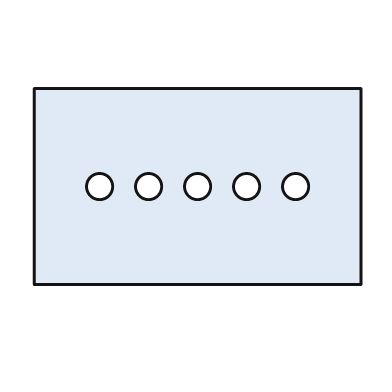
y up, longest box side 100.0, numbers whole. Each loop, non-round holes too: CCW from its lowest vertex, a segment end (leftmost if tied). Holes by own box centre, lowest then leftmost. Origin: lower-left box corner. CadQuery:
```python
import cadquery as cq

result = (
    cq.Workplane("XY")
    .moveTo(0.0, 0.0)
    .lineTo(100.0, 0.0)
    .lineTo(100.0, 60.0)
    .lineTo(0.0, 60.0)
    .close()
    .moveTo(20.0, 30.0)
    .circle(4.0)
    .moveTo(35.0, 30.0)
    .circle(4.0)
    .moveTo(50.0, 30.0)
    .circle(4.0)
    .moveTo(65.0, 30.0)
    .circle(4.0)
    .moveTo(80.0, 30.0)
    .circle(4.0)
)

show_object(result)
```